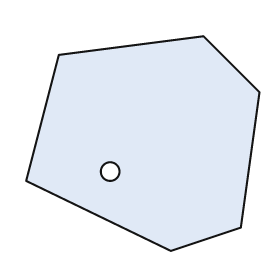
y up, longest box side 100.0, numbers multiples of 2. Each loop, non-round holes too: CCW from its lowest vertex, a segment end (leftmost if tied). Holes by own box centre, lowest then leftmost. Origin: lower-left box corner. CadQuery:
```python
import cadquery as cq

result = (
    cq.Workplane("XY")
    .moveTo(62.0, 0.0)
    .lineTo(92.0, 10.0)
    .lineTo(100.0, 68.0)
    .lineTo(76.0, 92.0)
    .lineTo(14.0, 84.0)
    .lineTo(0.0, 30.0)
    .close()
    .moveTo(36.0, 34.0)
    .circle(4.0)
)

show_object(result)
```